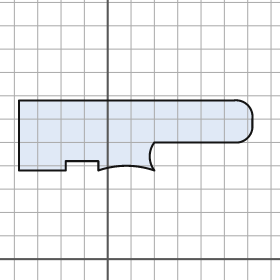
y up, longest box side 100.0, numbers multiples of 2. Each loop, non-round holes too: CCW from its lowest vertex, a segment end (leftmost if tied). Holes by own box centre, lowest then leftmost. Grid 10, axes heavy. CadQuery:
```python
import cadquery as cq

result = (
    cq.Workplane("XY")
    .moveTo(-38.0, 38.0)
    .lineTo(-18.0, 38.0)
    .lineTo(-18.0, 42.0)
    .lineTo(-4.0, 42.0)
    .lineTo(-4.0, 38.0)
    .threePointArc((8.0, 40.0), (20.0, 38.0))
    .threePointArc((18.0, 44.0), (20.0, 50.0))
    .lineTo(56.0, 50.0)
    .threePointArc((60.0, 52.0), (62.0, 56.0))
    .lineTo(62.0, 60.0)
    .threePointArc((60.0, 66.0), (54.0, 68.0))
    .lineTo(-38.0, 68.0)
    .close()
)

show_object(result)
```